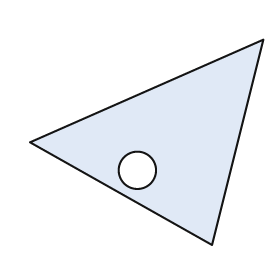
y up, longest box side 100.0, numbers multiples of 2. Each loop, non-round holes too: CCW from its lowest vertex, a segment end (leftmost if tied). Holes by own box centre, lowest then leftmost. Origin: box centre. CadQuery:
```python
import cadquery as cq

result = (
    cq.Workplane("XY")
    .moveTo(28.0, -44.0)
    .lineTo(50.0, 44.0)
    .lineTo(-50.0, 0.0)
    .close()
    .moveTo(-4.0, -12.0)
    .circle(8.0)
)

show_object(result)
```